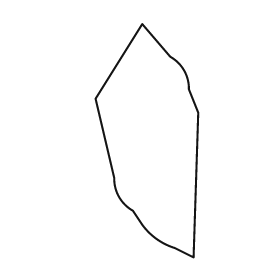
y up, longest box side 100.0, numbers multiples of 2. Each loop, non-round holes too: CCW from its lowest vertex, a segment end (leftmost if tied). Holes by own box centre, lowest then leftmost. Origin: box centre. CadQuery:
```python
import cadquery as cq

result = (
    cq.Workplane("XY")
    .moveTo(20.0, -50.0)
    .lineTo(22.0, 12.0)
    .lineTo(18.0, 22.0)
    .threePointArc((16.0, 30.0), (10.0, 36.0))
    .lineTo(-2.0, 50.0)
    .lineTo(-22.0, 18.0)
    .lineTo(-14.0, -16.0)
    .threePointArc((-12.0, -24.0), (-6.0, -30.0))
    .lineTo(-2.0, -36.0)
    .threePointArc((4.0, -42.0), (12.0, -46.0))
    .close()
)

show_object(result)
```